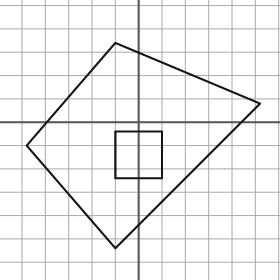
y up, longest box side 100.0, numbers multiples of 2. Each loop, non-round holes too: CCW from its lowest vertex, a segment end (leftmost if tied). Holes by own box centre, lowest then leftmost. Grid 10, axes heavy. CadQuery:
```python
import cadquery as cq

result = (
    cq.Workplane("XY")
    .moveTo(-10.0, -54.0)
    .lineTo(52.0, 8.0)
    .lineTo(-10.0, 34.0)
    .lineTo(-48.0, -10.0)
    .close()
    .moveTo(-10.0, -24.0)
    .lineTo(10.0, -24.0)
    .lineTo(10.0, -4.0)
    .lineTo(-10.0, -4.0)
    .close()
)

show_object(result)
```